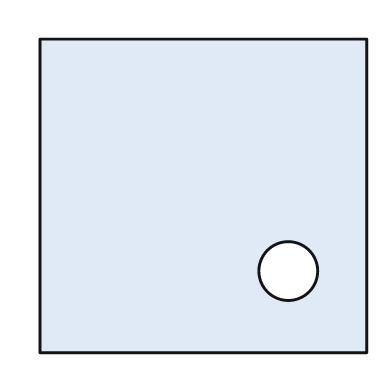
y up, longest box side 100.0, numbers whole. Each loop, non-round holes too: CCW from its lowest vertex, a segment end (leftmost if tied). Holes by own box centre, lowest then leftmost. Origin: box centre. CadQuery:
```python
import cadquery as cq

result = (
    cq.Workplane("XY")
    .moveTo(-50.0, -48.0)
    .lineTo(50.0, -48.0)
    .lineTo(50.0, 48.0)
    .lineTo(-50.0, 48.0)
    .close()
    .moveTo(26.0, -23.0)
    .circle(9.0)
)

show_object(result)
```